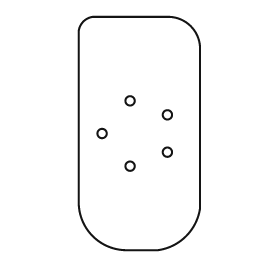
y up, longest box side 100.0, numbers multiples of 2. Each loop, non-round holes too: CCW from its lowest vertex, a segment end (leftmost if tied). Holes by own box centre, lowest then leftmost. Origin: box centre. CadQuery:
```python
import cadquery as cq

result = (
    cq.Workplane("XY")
    .moveTo(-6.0, -50.0)
    .lineTo(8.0, -50.0)
    .threePointArc((20.0, -44.0), (26.0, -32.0))
    .lineTo(26.0, 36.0)
    .threePointArc((22.0, 46.0), (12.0, 50.0))
    .lineTo(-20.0, 50.0)
    .threePointArc((-24.0, 48.0), (-26.0, 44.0))
    .lineTo(-26.0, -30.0)
    .threePointArc((-20.0, -44.0), (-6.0, -50.0))
    .close()
    .moveTo(-4.0, -14.0)
    .circle(2.0)
    .moveTo(12.0, -8.0)
    .circle(2.0)
    .moveTo(-16.0, 0.0)
    .circle(2.0)
    .moveTo(12.0, 8.0)
    .circle(2.0)
    .moveTo(-4.0, 14.0)
    .circle(2.0)
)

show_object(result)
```